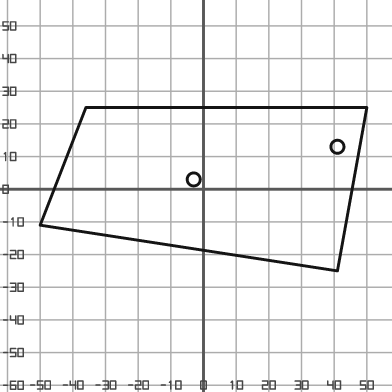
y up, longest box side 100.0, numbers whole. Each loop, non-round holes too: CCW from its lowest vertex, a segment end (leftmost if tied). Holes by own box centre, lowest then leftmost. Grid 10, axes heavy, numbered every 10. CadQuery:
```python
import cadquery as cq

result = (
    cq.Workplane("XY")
    .moveTo(41.0, -25.0)
    .lineTo(50.0, 25.0)
    .lineTo(-36.0, 25.0)
    .lineTo(-50.0, -11.0)
    .close()
    .moveTo(-3.0, 3.0)
    .circle(2.0)
    .moveTo(41.0, 13.0)
    .circle(2.0)
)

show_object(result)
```